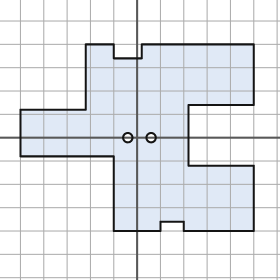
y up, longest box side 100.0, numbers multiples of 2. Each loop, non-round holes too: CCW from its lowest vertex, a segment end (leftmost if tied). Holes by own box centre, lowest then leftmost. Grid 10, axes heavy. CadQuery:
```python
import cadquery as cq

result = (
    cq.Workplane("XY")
    .moveTo(-10.0, -40.0)
    .lineTo(10.0, -40.0)
    .lineTo(10.0, -36.0)
    .lineTo(20.0, -36.0)
    .lineTo(20.0, -40.0)
    .lineTo(50.0, -40.0)
    .lineTo(50.0, -12.0)
    .lineTo(22.0, -12.0)
    .lineTo(22.0, 14.0)
    .lineTo(50.0, 14.0)
    .lineTo(50.0, 40.0)
    .lineTo(2.0, 40.0)
    .lineTo(2.0, 34.0)
    .lineTo(-10.0, 34.0)
    .lineTo(-10.0, 40.0)
    .lineTo(-22.0, 40.0)
    .lineTo(-22.0, 12.0)
    .lineTo(-50.0, 12.0)
    .lineTo(-50.0, -8.0)
    .lineTo(-10.0, -8.0)
    .close()
    .moveTo(-4.0, 0.0)
    .circle(2.0)
    .moveTo(6.0, 0.0)
    .circle(2.0)
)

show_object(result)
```